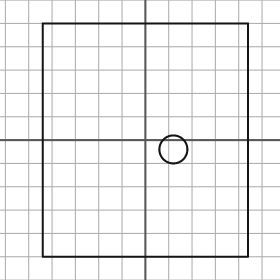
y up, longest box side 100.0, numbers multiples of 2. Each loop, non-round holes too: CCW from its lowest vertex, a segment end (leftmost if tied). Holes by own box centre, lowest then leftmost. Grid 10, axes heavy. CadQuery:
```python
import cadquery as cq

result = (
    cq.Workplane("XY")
    .moveTo(-44.0, -50.0)
    .lineTo(44.0, -50.0)
    .lineTo(44.0, 50.0)
    .lineTo(-44.0, 50.0)
    .close()
    .moveTo(12.0, -4.0)
    .circle(6.0)
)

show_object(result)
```